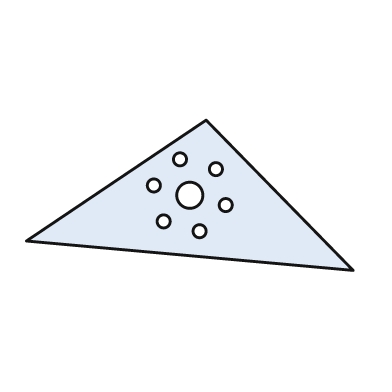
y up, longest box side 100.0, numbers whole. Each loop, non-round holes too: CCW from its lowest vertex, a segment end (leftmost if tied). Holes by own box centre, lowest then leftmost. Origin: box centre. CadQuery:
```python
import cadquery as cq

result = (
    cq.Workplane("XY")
    .moveTo(50.0, -23.0)
    .lineTo(5.0, 23.0)
    .lineTo(-50.0, -14.0)
    .close()
    .moveTo(3.0, -11.0)
    .circle(2.0)
    .moveTo(-8.0, -8.0)
    .circle(2.0)
    .moveTo(11.0, -3.0)
    .circle(2.0)
    .moveTo(0.0, 0.0)
    .circle(4.0)
    .moveTo(-11.0, 3.0)
    .circle(2.0)
    .moveTo(8.0, 8.0)
    .circle(2.0)
    .moveTo(-3.0, 11.0)
    .circle(2.0)
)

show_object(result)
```